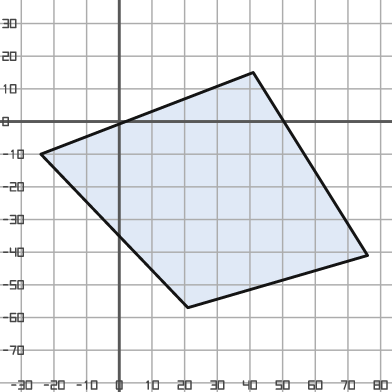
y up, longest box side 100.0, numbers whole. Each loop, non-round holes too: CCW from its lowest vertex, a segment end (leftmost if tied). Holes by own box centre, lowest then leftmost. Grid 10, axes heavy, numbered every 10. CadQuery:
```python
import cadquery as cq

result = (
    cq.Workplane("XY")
    .moveTo(21.0, -57.0)
    .lineTo(76.0, -41.0)
    .lineTo(41.0, 15.0)
    .lineTo(-24.0, -10.0)
    .close()
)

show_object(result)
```